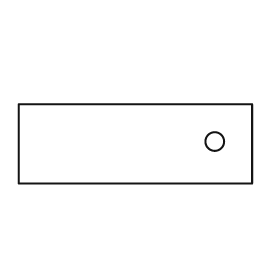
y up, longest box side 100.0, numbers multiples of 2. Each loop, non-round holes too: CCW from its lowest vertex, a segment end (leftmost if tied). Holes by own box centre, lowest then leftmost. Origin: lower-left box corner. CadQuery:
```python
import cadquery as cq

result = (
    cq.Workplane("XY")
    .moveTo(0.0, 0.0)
    .lineTo(100.0, 0.0)
    .lineTo(100.0, 34.0)
    .lineTo(0.0, 34.0)
    .close()
    .moveTo(84.0, 18.0)
    .circle(4.0)
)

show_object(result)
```